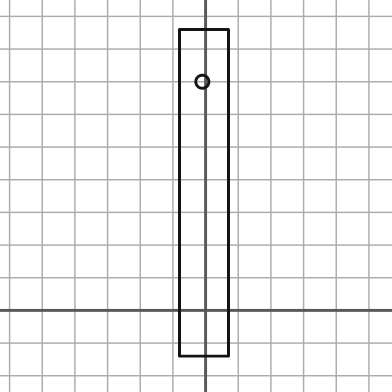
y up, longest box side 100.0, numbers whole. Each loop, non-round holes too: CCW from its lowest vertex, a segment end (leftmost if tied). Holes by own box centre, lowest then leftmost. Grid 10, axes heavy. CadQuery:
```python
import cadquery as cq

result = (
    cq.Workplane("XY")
    .moveTo(-8.0, -14.0)
    .lineTo(7.0, -14.0)
    .lineTo(7.0, 86.0)
    .lineTo(-8.0, 86.0)
    .close()
    .moveTo(-1.0, 70.0)
    .circle(2.0)
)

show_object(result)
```